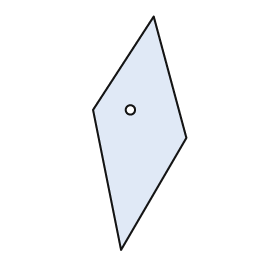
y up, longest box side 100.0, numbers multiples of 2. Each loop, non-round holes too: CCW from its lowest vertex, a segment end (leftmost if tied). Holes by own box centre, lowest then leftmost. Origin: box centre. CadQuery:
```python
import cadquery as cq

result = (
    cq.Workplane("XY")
    .moveTo(-8.0, -50.0)
    .lineTo(20.0, -2.0)
    .lineTo(6.0, 50.0)
    .lineTo(-20.0, 10.0)
    .close()
    .moveTo(-4.0, 10.0)
    .circle(2.0)
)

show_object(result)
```